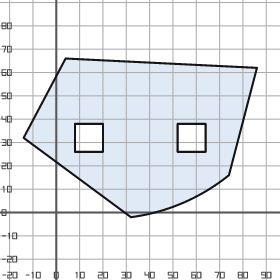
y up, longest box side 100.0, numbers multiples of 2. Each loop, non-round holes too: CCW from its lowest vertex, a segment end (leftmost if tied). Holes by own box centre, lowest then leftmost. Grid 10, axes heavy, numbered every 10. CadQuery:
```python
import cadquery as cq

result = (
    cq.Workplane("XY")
    .moveTo(32.0, -2.0)
    .threePointArc((54.0, 4.0), (74.0, 16.0))
    .lineTo(86.0, 62.0)
    .lineTo(4.0, 66.0)
    .lineTo(-14.0, 32.0)
    .close()
    .moveTo(8.0, 26.0)
    .lineTo(20.0, 26.0)
    .lineTo(20.0, 38.0)
    .lineTo(8.0, 38.0)
    .close()
    .moveTo(52.0, 26.0)
    .lineTo(64.0, 26.0)
    .lineTo(64.0, 38.0)
    .lineTo(52.0, 38.0)
    .close()
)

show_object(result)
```